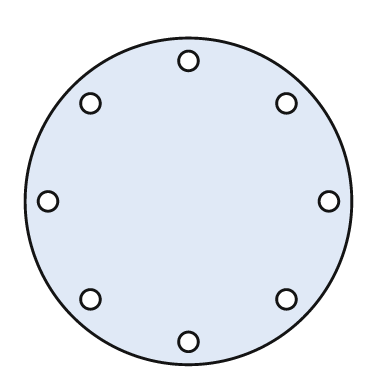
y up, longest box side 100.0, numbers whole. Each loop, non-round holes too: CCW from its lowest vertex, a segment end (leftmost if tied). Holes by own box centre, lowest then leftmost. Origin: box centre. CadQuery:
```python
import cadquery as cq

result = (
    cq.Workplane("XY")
    .moveTo(0.0, 0.0)
    .circle(50.0)
    .moveTo(0.0, -43.0)
    .circle(3.0)
    .moveTo(-30.0, -30.0)
    .circle(3.0)
    .moveTo(30.0, -30.0)
    .circle(3.0)
    .moveTo(-43.0, 0.0)
    .circle(3.0)
    .moveTo(43.0, 0.0)
    .circle(3.0)
    .moveTo(-30.0, 30.0)
    .circle(3.0)
    .moveTo(30.0, 30.0)
    .circle(3.0)
    .moveTo(0.0, 43.0)
    .circle(3.0)
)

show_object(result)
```